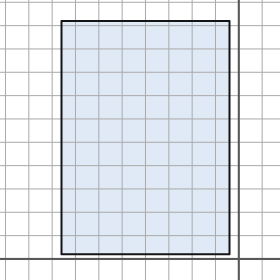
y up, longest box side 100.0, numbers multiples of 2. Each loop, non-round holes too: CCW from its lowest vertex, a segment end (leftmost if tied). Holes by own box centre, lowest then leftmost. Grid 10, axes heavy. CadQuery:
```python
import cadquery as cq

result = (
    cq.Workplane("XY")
    .moveTo(-76.0, 2.0)
    .lineTo(-4.0, 2.0)
    .lineTo(-4.0, 102.0)
    .lineTo(-76.0, 102.0)
    .close()
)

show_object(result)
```